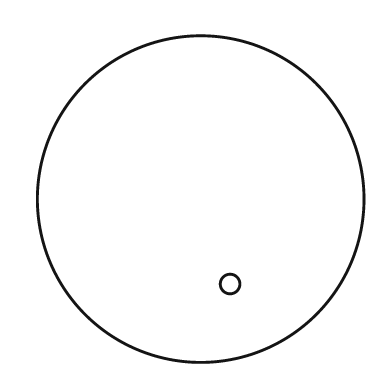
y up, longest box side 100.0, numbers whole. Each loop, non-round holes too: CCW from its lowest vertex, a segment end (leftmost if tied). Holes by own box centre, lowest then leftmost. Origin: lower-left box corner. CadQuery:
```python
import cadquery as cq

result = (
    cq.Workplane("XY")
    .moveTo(50.0, 50.0)
    .circle(50.0)
    .moveTo(59.0, 24.0)
    .circle(3.0)
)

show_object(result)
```